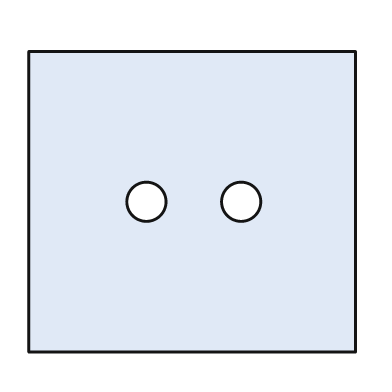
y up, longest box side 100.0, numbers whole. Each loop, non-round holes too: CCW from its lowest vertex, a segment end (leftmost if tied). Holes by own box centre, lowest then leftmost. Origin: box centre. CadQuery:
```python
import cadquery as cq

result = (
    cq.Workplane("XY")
    .moveTo(-50.0, -46.0)
    .lineTo(50.0, -46.0)
    .lineTo(50.0, 46.0)
    .lineTo(-50.0, 46.0)
    .close()
    .moveTo(-14.0, 0.0)
    .circle(6.0)
    .moveTo(15.0, 0.0)
    .circle(6.0)
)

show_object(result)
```